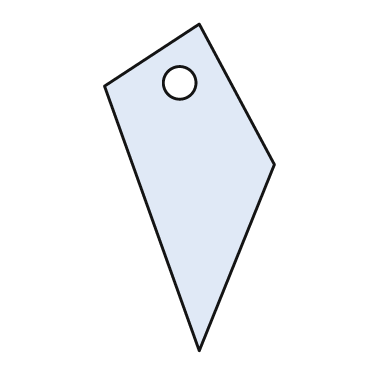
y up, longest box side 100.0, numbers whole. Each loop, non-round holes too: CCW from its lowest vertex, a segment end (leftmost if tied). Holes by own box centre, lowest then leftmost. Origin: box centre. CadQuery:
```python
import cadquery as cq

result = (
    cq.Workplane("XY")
    .moveTo(3.0, -50.0)
    .lineTo(26.0, 7.0)
    .lineTo(3.0, 50.0)
    .lineTo(-26.0, 31.0)
    .close()
    .moveTo(-3.0, 32.0)
    .circle(5.0)
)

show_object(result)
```